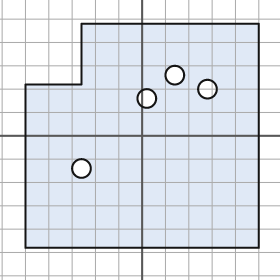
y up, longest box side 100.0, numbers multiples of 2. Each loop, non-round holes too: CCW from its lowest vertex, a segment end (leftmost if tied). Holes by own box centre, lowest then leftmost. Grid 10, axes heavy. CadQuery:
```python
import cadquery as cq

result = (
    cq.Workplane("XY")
    .moveTo(-50.0, -48.0)
    .lineTo(50.0, -48.0)
    .lineTo(50.0, 48.0)
    .lineTo(-26.0, 48.0)
    .lineTo(-26.0, 22.0)
    .lineTo(-50.0, 22.0)
    .close()
    .moveTo(-26.0, -14.0)
    .circle(4.0)
    .moveTo(2.0, 16.0)
    .circle(4.0)
    .moveTo(28.0, 20.0)
    .circle(4.0)
    .moveTo(14.0, 26.0)
    .circle(4.0)
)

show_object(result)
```